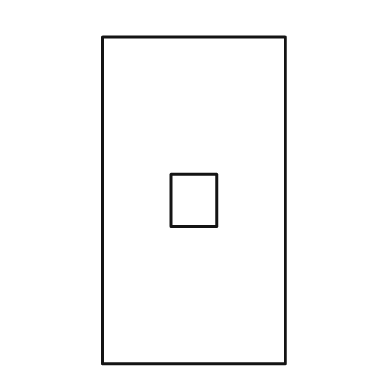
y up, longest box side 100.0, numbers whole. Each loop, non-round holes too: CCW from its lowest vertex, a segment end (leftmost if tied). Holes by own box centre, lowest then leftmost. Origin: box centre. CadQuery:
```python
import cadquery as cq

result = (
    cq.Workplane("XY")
    .moveTo(-28.0, -50.0)
    .lineTo(28.0, -50.0)
    .lineTo(28.0, 50.0)
    .lineTo(-28.0, 50.0)
    .close()
    .moveTo(-7.0, -8.0)
    .lineTo(7.0, -8.0)
    .lineTo(7.0, 8.0)
    .lineTo(-7.0, 8.0)
    .close()
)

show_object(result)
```